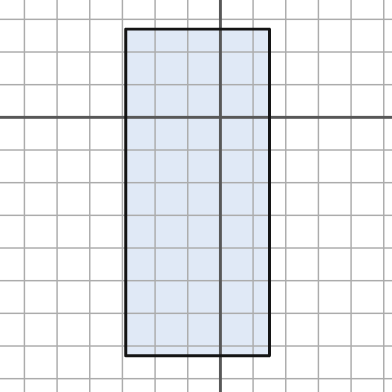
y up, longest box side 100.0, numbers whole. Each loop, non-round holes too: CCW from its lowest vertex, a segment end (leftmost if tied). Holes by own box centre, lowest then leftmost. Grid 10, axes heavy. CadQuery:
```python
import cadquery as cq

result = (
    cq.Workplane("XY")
    .moveTo(-29.0, -73.0)
    .lineTo(15.0, -73.0)
    .lineTo(15.0, 27.0)
    .lineTo(-29.0, 27.0)
    .close()
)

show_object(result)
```